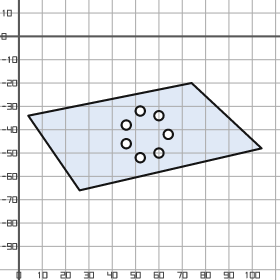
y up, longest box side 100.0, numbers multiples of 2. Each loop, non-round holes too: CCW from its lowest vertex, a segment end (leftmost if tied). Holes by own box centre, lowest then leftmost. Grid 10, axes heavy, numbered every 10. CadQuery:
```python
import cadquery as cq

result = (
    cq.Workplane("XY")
    .moveTo(26.0, -66.0)
    .lineTo(104.0, -48.0)
    .lineTo(74.0, -20.0)
    .lineTo(4.0, -34.0)
    .close()
    .moveTo(52.0, -52.0)
    .circle(2.0)
    .moveTo(60.0, -50.0)
    .circle(2.0)
    .moveTo(46.0, -46.0)
    .circle(2.0)
    .moveTo(64.0, -42.0)
    .circle(2.0)
    .moveTo(46.0, -38.0)
    .circle(2.0)
    .moveTo(60.0, -34.0)
    .circle(2.0)
    .moveTo(52.0, -32.0)
    .circle(2.0)
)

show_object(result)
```